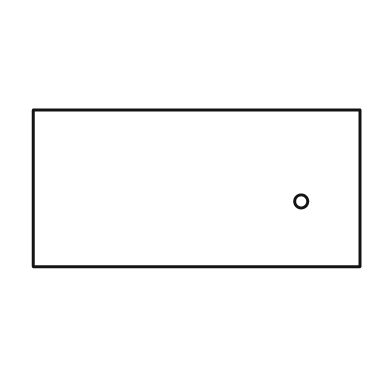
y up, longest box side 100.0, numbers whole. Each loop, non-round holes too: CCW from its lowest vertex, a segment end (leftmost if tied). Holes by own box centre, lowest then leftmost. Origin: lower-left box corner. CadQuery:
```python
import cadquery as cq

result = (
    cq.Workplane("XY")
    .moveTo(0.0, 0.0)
    .lineTo(100.0, 0.0)
    .lineTo(100.0, 48.0)
    .lineTo(0.0, 48.0)
    .close()
    .moveTo(82.0, 20.0)
    .circle(2.0)
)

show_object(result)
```